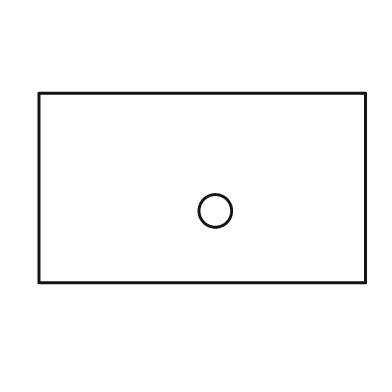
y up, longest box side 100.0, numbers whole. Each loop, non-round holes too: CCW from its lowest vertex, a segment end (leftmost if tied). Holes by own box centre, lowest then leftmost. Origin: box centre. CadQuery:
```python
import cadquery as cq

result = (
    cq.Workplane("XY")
    .moveTo(-50.0, -29.0)
    .lineTo(50.0, -29.0)
    .lineTo(50.0, 29.0)
    .lineTo(-50.0, 29.0)
    .close()
    .moveTo(4.0, -7.0)
    .circle(5.0)
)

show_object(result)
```